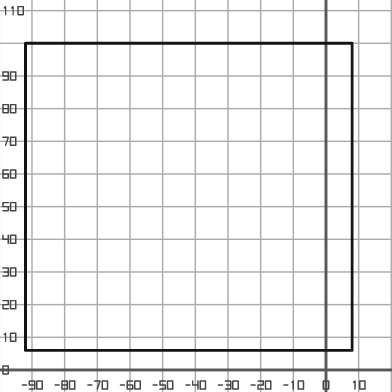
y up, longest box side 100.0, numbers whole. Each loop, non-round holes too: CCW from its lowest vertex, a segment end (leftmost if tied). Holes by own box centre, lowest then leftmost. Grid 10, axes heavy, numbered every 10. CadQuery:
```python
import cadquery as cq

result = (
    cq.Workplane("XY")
    .moveTo(-92.0, 6.0)
    .lineTo(8.0, 6.0)
    .lineTo(8.0, 100.0)
    .lineTo(-92.0, 100.0)
    .close()
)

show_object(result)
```